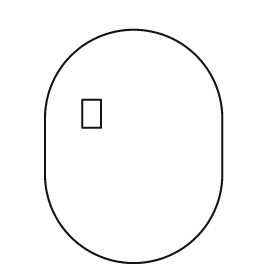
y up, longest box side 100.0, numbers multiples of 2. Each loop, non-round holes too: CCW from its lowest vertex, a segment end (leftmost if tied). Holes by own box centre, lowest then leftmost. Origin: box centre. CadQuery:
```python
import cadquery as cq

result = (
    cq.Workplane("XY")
    .moveTo(-38.0, -12.0)
    .threePointArc((0.0, -50.0), (38.0, -12.0))
    .lineTo(38.0, 12.0)
    .threePointArc((0.0, 50.0), (-38.0, 12.0))
    .close()
    .moveTo(-22.0, 8.0)
    .lineTo(-14.0, 8.0)
    .lineTo(-14.0, 20.0)
    .lineTo(-22.0, 20.0)
    .close()
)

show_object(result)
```